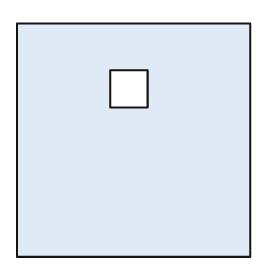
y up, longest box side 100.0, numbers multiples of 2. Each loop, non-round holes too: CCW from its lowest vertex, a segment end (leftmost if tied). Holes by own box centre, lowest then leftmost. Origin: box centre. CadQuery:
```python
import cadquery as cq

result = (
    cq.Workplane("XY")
    .moveTo(-50.0, -50.0)
    .lineTo(50.0, -50.0)
    .lineTo(50.0, 50.0)
    .lineTo(-50.0, 50.0)
    .close()
    .moveTo(-10.0, 14.0)
    .lineTo(6.0, 14.0)
    .lineTo(6.0, 30.0)
    .lineTo(-10.0, 30.0)
    .close()
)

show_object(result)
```